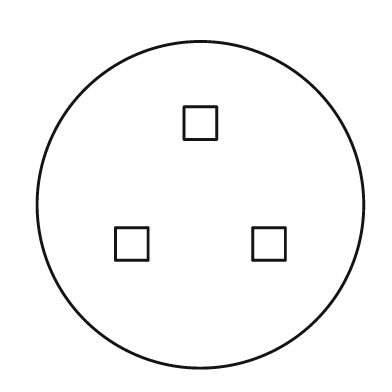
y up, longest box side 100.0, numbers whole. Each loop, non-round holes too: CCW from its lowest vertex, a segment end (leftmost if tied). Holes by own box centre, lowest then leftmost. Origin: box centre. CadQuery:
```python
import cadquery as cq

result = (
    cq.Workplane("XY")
    .moveTo(0.0, 0.0)
    .circle(50.0)
    .moveTo(-26.0, -17.0)
    .lineTo(-16.0, -17.0)
    .lineTo(-16.0, -7.0)
    .lineTo(-26.0, -7.0)
    .close()
    .moveTo(16.0, -17.0)
    .lineTo(26.0, -17.0)
    .lineTo(26.0, -7.0)
    .lineTo(16.0, -7.0)
    .close()
    .moveTo(-5.0, 20.0)
    .lineTo(5.0, 20.0)
    .lineTo(5.0, 30.0)
    .lineTo(-5.0, 30.0)
    .close()
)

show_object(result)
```